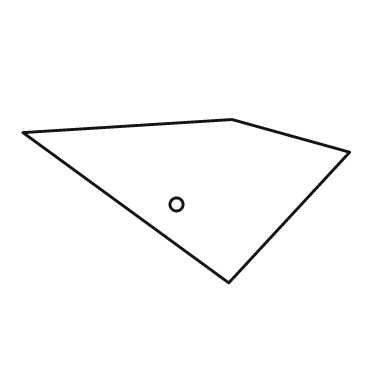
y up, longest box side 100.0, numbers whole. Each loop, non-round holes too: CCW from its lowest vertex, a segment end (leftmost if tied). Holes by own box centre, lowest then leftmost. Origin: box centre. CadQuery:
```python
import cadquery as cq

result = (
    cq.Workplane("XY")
    .moveTo(13.0, -25.0)
    .lineTo(50.0, 15.0)
    .lineTo(14.0, 25.0)
    .lineTo(-50.0, 21.0)
    .close()
    .moveTo(-3.0, -1.0)
    .circle(2.0)
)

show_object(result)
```